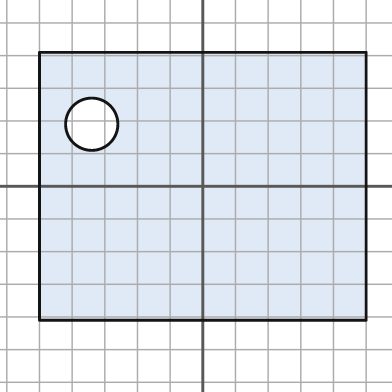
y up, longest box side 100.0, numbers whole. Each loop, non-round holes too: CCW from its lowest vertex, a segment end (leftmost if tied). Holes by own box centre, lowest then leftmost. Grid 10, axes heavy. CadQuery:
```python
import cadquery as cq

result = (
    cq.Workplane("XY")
    .moveTo(-50.0, -41.0)
    .lineTo(50.0, -41.0)
    .lineTo(50.0, 41.0)
    .lineTo(-50.0, 41.0)
    .close()
    .moveTo(-34.0, 19.0)
    .circle(8.0)
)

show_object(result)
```